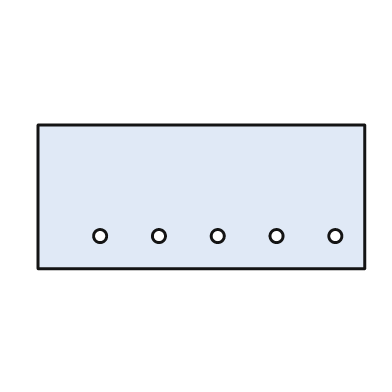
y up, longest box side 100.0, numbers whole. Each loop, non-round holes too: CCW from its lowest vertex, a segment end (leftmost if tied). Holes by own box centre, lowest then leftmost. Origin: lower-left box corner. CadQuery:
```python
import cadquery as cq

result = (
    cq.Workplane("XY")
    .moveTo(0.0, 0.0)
    .lineTo(100.0, 0.0)
    .lineTo(100.0, 44.0)
    .lineTo(0.0, 44.0)
    .close()
    .moveTo(19.0, 10.0)
    .circle(2.0)
    .moveTo(37.0, 10.0)
    .circle(2.0)
    .moveTo(55.0, 10.0)
    .circle(2.0)
    .moveTo(73.0, 10.0)
    .circle(2.0)
    .moveTo(91.0, 10.0)
    .circle(2.0)
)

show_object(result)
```